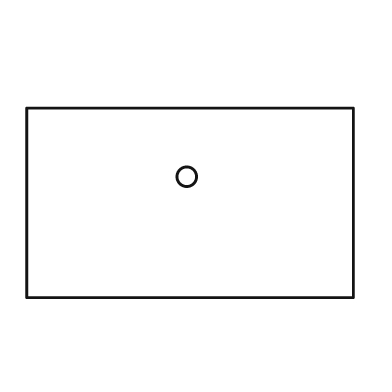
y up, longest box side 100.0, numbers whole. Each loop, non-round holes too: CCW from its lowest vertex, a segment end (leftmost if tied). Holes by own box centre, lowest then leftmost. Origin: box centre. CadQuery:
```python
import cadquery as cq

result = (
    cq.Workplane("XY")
    .moveTo(-50.0, -29.0)
    .lineTo(50.0, -29.0)
    .lineTo(50.0, 29.0)
    .lineTo(-50.0, 29.0)
    .close()
    .moveTo(-1.0, 8.0)
    .circle(3.0)
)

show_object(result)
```